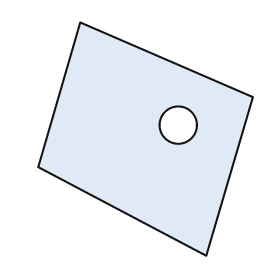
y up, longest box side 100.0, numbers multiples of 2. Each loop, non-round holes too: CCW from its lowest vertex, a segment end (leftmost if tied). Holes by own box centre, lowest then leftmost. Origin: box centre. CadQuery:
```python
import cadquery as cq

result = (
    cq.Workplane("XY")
    .moveTo(26.0, -50.0)
    .lineTo(46.0, 18.0)
    .lineTo(-28.0, 50.0)
    .lineTo(-46.0, -12.0)
    .close()
    .moveTo(14.0, 6.0)
    .circle(8.0)
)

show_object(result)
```